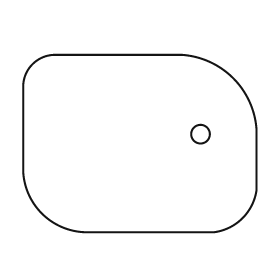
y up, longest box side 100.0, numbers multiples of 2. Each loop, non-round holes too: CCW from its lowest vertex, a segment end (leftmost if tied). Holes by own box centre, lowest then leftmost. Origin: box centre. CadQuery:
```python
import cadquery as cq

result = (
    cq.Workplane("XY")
    .moveTo(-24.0, -38.0)
    .lineTo(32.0, -38.0)
    .threePointArc((44.0, -32.0), (50.0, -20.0))
    .lineTo(50.0, 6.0)
    .threePointArc((40.0, 28.0), (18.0, 38.0))
    .lineTo(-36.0, 38.0)
    .threePointArc((-46.0, 34.0), (-50.0, 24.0))
    .lineTo(-50.0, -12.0)
    .threePointArc((-42.0, -30.0), (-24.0, -38.0))
    .close()
    .moveTo(26.0, 4.0)
    .circle(4.0)
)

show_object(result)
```